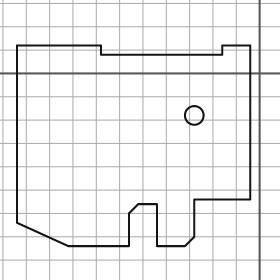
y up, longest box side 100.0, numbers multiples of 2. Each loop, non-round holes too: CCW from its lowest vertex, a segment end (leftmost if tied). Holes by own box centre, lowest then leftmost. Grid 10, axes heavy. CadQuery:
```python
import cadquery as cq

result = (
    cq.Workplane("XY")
    .moveTo(-82.0, -74.0)
    .lineTo(-56.0, -74.0)
    .lineTo(-56.0, -60.0)
    .lineTo(-52.0, -56.0)
    .lineTo(-44.0, -56.0)
    .lineTo(-44.0, -74.0)
    .lineTo(-32.0, -74.0)
    .lineTo(-28.0, -70.0)
    .lineTo(-28.0, -54.0)
    .lineTo(-4.0, -54.0)
    .lineTo(-4.0, 12.0)
    .lineTo(-16.0, 12.0)
    .lineTo(-16.0, 8.0)
    .lineTo(-68.0, 8.0)
    .lineTo(-68.0, 12.0)
    .lineTo(-104.0, 12.0)
    .lineTo(-104.0, -64.0)
    .close()
    .moveTo(-28.0, -18.0)
    .circle(4.0)
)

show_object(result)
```